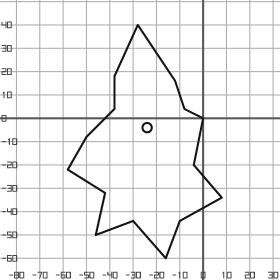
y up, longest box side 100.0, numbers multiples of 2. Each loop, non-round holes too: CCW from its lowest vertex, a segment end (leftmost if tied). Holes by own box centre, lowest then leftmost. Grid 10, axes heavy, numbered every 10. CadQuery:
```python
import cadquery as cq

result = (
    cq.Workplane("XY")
    .moveTo(-16.0, -60.0)
    .lineTo(-10.0, -44.0)
    .lineTo(8.0, -34.0)
    .lineTo(-4.0, -20.0)
    .lineTo(0.0, 0.0)
    .lineTo(-8.0, 4.0)
    .lineTo(-12.0, 16.0)
    .lineTo(-28.0, 40.0)
    .lineTo(-38.0, 18.0)
    .lineTo(-38.0, 4.0)
    .lineTo(-50.0, -8.0)
    .lineTo(-58.0, -22.0)
    .lineTo(-42.0, -32.0)
    .lineTo(-46.0, -50.0)
    .lineTo(-30.0, -44.0)
    .close()
    .moveTo(-24.0, -4.0)
    .circle(2.0)
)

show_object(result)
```